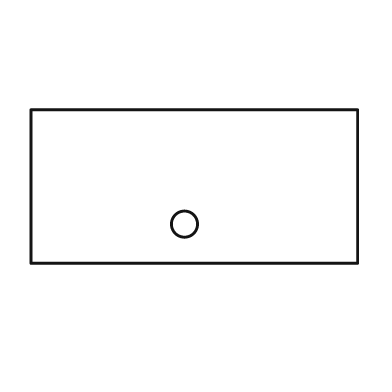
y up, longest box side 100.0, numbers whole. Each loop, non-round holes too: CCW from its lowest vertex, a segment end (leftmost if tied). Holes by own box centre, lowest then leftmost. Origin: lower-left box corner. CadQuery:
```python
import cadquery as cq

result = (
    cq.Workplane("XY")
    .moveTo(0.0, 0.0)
    .lineTo(100.0, 0.0)
    .lineTo(100.0, 47.0)
    .lineTo(0.0, 47.0)
    .close()
    .moveTo(47.0, 12.0)
    .circle(4.0)
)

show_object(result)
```